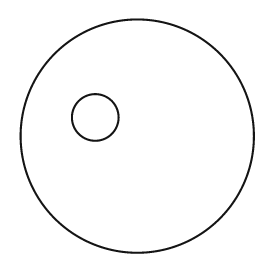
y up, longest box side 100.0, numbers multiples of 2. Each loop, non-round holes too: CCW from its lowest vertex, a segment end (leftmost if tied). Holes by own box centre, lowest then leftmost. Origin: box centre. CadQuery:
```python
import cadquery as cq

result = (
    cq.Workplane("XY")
    .moveTo(0.0, 0.0)
    .circle(50.0)
    .moveTo(-18.0, 8.0)
    .circle(10.0)
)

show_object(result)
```